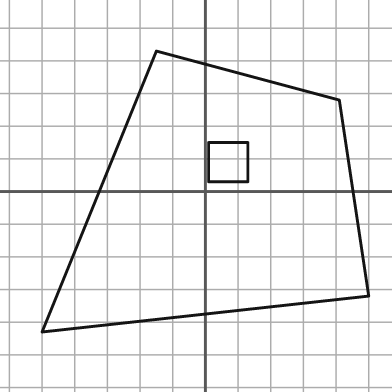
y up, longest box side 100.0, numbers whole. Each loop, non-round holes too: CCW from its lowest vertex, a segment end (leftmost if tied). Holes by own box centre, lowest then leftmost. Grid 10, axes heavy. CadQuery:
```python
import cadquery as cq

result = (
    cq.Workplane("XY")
    .moveTo(-50.0, -43.0)
    .lineTo(50.0, -32.0)
    .lineTo(41.0, 28.0)
    .lineTo(-15.0, 43.0)
    .close()
    .moveTo(1.0, 3.0)
    .lineTo(13.0, 3.0)
    .lineTo(13.0, 15.0)
    .lineTo(1.0, 15.0)
    .close()
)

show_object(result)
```